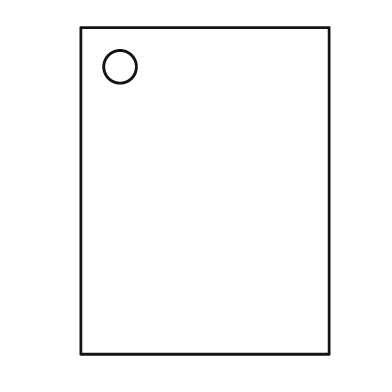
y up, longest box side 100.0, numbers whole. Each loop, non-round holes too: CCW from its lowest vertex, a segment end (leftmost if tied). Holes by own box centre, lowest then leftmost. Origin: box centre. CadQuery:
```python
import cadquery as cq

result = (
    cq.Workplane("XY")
    .moveTo(-38.0, -50.0)
    .lineTo(38.0, -50.0)
    .lineTo(38.0, 50.0)
    .lineTo(-38.0, 50.0)
    .close()
    .moveTo(-26.0, 38.0)
    .circle(5.0)
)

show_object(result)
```